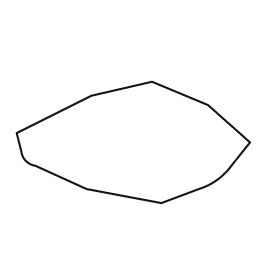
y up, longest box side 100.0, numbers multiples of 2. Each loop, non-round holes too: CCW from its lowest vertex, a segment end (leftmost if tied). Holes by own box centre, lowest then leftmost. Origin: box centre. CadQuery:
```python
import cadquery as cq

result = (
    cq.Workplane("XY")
    .moveTo(12.0, -26.0)
    .lineTo(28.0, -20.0)
    .threePointArc((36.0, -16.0), (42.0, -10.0))
    .lineTo(50.0, 0.0)
    .lineTo(32.0, 16.0)
    .lineTo(8.0, 26.0)
    .lineTo(-18.0, 20.0)
    .lineTo(-50.0, 4.0)
    .lineTo(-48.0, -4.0)
    .threePointArc((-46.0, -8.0), (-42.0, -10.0))
    .lineTo(-20.0, -20.0)
    .close()
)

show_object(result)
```